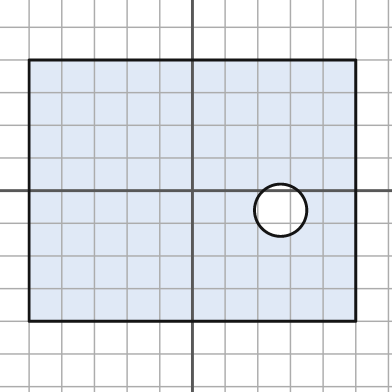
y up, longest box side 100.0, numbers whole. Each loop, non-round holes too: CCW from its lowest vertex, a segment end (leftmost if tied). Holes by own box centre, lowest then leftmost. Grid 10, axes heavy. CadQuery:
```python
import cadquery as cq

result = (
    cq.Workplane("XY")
    .moveTo(-50.0, -40.0)
    .lineTo(50.0, -40.0)
    .lineTo(50.0, 40.0)
    .lineTo(-50.0, 40.0)
    .close()
    .moveTo(27.0, -6.0)
    .circle(8.0)
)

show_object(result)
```